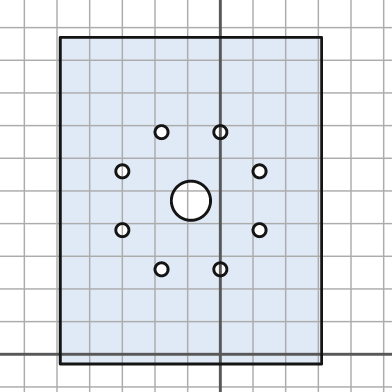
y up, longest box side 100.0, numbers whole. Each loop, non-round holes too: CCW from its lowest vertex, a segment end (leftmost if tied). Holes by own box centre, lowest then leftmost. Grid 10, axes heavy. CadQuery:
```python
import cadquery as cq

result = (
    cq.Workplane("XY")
    .moveTo(-49.0, -3.0)
    .lineTo(31.0, -3.0)
    .lineTo(31.0, 97.0)
    .lineTo(-49.0, 97.0)
    .close()
    .moveTo(-18.0, 26.0)
    .circle(2.0)
    .moveTo(0.0, 26.0)
    .circle(2.0)
    .moveTo(-30.0, 38.0)
    .circle(2.0)
    .moveTo(12.0, 38.0)
    .circle(2.0)
    .moveTo(-9.0, 47.0)
    .circle(6.0)
    .moveTo(-30.0, 56.0)
    .circle(2.0)
    .moveTo(12.0, 56.0)
    .circle(2.0)
    .moveTo(-18.0, 68.0)
    .circle(2.0)
    .moveTo(0.0, 68.0)
    .circle(2.0)
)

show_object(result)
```